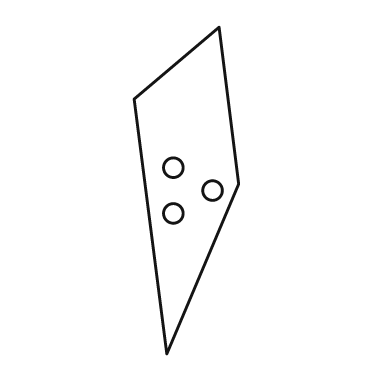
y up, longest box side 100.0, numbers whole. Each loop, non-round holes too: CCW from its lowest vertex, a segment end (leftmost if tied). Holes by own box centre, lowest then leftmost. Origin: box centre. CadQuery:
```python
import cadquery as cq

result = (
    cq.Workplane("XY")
    .moveTo(-6.0, -50.0)
    .lineTo(16.0, 2.0)
    .lineTo(10.0, 50.0)
    .lineTo(-16.0, 28.0)
    .close()
    .moveTo(-4.0, -7.0)
    .circle(3.0)
    .moveTo(8.0, 0.0)
    .circle(3.0)
    .moveTo(-4.0, 7.0)
    .circle(3.0)
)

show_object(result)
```